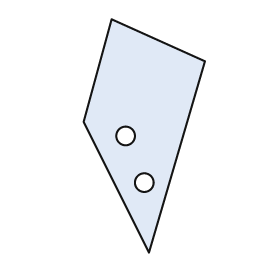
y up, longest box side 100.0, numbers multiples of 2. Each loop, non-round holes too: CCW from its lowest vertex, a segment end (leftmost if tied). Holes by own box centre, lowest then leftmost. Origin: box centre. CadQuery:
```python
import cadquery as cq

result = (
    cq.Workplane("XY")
    .moveTo(2.0, -50.0)
    .lineTo(26.0, 32.0)
    .lineTo(-14.0, 50.0)
    .lineTo(-26.0, 6.0)
    .close()
    .moveTo(0.0, -20.0)
    .circle(4.0)
    .moveTo(-8.0, 0.0)
    .circle(4.0)
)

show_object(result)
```